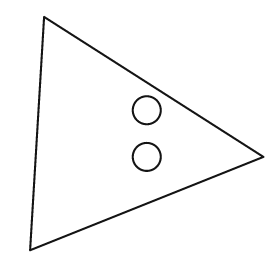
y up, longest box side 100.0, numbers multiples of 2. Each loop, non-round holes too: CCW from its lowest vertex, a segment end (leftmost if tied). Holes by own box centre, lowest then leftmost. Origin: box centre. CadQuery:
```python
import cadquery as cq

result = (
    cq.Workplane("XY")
    .moveTo(-50.0, -50.0)
    .lineTo(50.0, -10.0)
    .lineTo(-44.0, 50.0)
    .close()
    .moveTo(0.0, -10.0)
    .circle(6.0)
    .moveTo(0.0, 10.0)
    .circle(6.0)
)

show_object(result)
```